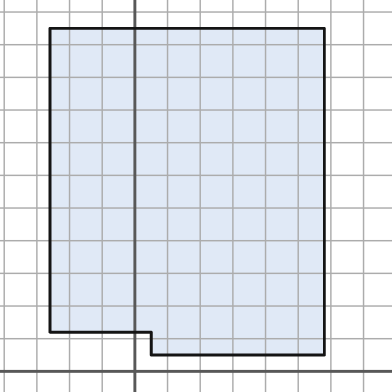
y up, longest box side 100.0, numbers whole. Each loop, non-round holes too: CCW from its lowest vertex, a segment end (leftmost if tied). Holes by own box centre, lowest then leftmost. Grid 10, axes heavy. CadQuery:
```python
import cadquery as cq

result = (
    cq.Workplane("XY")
    .moveTo(5.0, 5.0)
    .lineTo(58.0, 5.0)
    .lineTo(58.0, 105.0)
    .lineTo(-26.0, 105.0)
    .lineTo(-26.0, 12.0)
    .lineTo(5.0, 12.0)
    .close()
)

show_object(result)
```